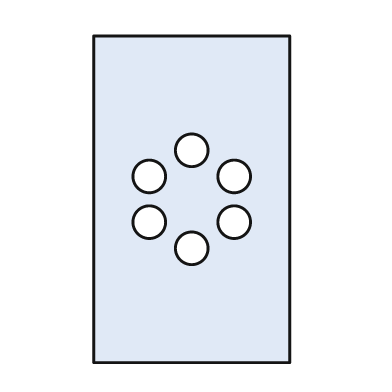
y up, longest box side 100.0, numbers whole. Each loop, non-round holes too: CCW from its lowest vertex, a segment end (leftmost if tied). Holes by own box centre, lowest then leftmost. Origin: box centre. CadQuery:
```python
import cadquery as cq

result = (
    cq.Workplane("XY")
    .moveTo(-30.0, -50.0)
    .lineTo(30.0, -50.0)
    .lineTo(30.0, 50.0)
    .lineTo(-30.0, 50.0)
    .close()
    .moveTo(0.0, -15.0)
    .circle(5.0)
    .moveTo(-13.0, -7.0)
    .circle(5.0)
    .moveTo(13.0, -7.0)
    .circle(5.0)
    .moveTo(-13.0, 7.0)
    .circle(5.0)
    .moveTo(13.0, 7.0)
    .circle(5.0)
    .moveTo(0.0, 15.0)
    .circle(5.0)
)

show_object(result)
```